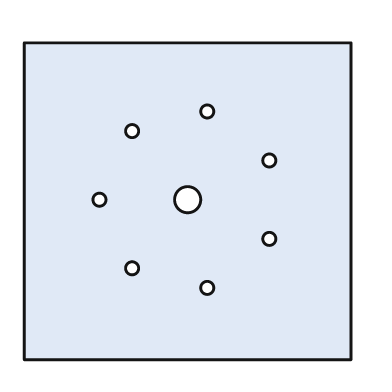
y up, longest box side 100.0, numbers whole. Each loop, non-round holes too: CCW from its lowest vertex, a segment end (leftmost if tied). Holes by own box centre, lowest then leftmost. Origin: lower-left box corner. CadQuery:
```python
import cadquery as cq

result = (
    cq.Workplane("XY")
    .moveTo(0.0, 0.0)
    .lineTo(100.0, 0.0)
    .lineTo(100.0, 97.0)
    .lineTo(0.0, 97.0)
    .close()
    .moveTo(56.0, 22.0)
    .circle(2.0)
    .moveTo(33.0, 28.0)
    .circle(2.0)
    .moveTo(75.0, 37.0)
    .circle(2.0)
    .moveTo(23.0, 49.0)
    .circle(2.0)
    .moveTo(50.0, 49.0)
    .circle(4.0)
    .moveTo(75.0, 61.0)
    .circle(2.0)
    .moveTo(33.0, 70.0)
    .circle(2.0)
    .moveTo(56.0, 76.0)
    .circle(2.0)
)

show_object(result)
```